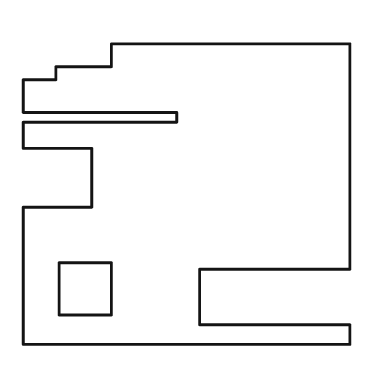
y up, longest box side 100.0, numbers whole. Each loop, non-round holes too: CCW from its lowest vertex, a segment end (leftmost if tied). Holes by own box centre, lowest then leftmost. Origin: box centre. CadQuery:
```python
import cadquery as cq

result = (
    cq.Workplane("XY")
    .moveTo(-50.0, -46.0)
    .lineTo(50.0, -46.0)
    .lineTo(50.0, -40.0)
    .lineTo(4.0, -40.0)
    .lineTo(4.0, -23.0)
    .lineTo(50.0, -23.0)
    .lineTo(50.0, 46.0)
    .lineTo(-23.0, 46.0)
    .lineTo(-23.0, 39.0)
    .lineTo(-40.0, 39.0)
    .lineTo(-40.0, 35.0)
    .lineTo(-50.0, 35.0)
    .lineTo(-50.0, 25.0)
    .lineTo(-3.0, 25.0)
    .lineTo(-3.0, 22.0)
    .lineTo(-50.0, 22.0)
    .lineTo(-50.0, 14.0)
    .lineTo(-29.0, 14.0)
    .lineTo(-29.0, -4.0)
    .lineTo(-50.0, -4.0)
    .close()
    .moveTo(-39.0, -37.0)
    .lineTo(-23.0, -37.0)
    .lineTo(-23.0, -21.0)
    .lineTo(-39.0, -21.0)
    .close()
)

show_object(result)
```